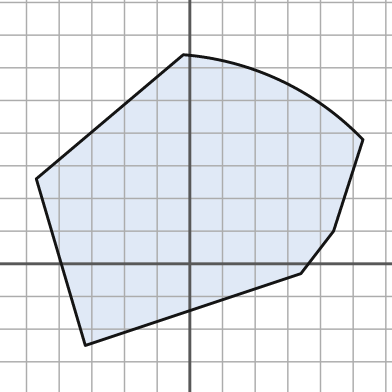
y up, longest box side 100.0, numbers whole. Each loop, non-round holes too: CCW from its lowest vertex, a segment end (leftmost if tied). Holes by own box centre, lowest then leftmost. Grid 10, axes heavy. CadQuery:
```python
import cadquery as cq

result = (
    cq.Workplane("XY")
    .moveTo(-32.0, -25.0)
    .lineTo(34.0, -3.0)
    .lineTo(44.0, 10.0)
    .lineTo(53.0, 38.0)
    .threePointArc((28.0, 56.0), (-2.0, 64.0))
    .lineTo(-47.0, 26.0)
    .close()
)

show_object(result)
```